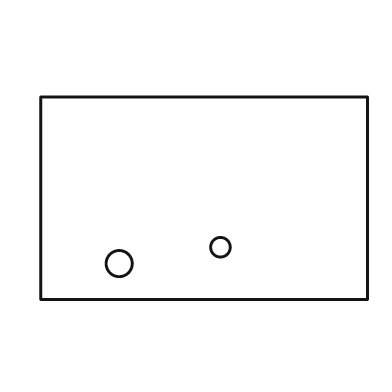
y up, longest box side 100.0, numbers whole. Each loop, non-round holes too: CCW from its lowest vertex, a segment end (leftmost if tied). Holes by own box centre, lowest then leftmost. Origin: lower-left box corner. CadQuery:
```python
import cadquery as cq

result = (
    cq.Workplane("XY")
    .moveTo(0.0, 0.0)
    .lineTo(100.0, 0.0)
    .lineTo(100.0, 62.0)
    .lineTo(0.0, 62.0)
    .close()
    .moveTo(24.0, 11.0)
    .circle(4.0)
    .moveTo(55.0, 16.0)
    .circle(3.0)
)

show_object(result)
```